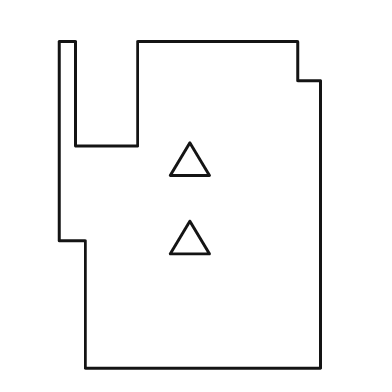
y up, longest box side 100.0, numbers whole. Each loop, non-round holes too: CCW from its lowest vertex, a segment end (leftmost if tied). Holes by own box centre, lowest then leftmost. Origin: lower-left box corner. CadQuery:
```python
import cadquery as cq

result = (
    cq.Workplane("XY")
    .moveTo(8.0, 0.0)
    .lineTo(80.0, 0.0)
    .lineTo(80.0, 88.0)
    .lineTo(73.0, 88.0)
    .lineTo(73.0, 100.0)
    .lineTo(24.0, 100.0)
    .lineTo(24.0, 68.0)
    .lineTo(5.0, 68.0)
    .lineTo(5.0, 100.0)
    .lineTo(0.0, 100.0)
    .lineTo(0.0, 39.0)
    .lineTo(8.0, 39.0)
    .close()
    .moveTo(34.0, 35.0)
    .lineTo(46.0, 35.0)
    .lineTo(40.0, 45.0)
    .close()
    .moveTo(34.0, 59.0)
    .lineTo(46.0, 59.0)
    .lineTo(40.0, 69.0)
    .close()
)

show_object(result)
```